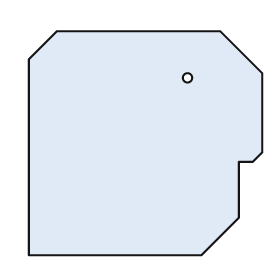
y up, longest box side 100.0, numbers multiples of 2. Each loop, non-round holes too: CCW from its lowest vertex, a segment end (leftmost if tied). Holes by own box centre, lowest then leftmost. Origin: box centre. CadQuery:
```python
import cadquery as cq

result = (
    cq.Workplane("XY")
    .moveTo(-50.0, -48.0)
    .lineTo(24.0, -48.0)
    .lineTo(40.0, -32.0)
    .lineTo(40.0, -8.0)
    .lineTo(46.0, -8.0)
    .lineTo(50.0, -4.0)
    .lineTo(50.0, 30.0)
    .lineTo(32.0, 48.0)
    .lineTo(-38.0, 48.0)
    .lineTo(-50.0, 36.0)
    .close()
    .moveTo(18.0, 28.0)
    .circle(2.0)
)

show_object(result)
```